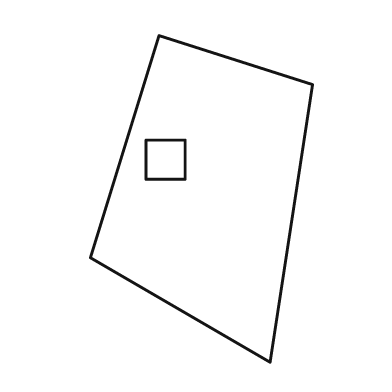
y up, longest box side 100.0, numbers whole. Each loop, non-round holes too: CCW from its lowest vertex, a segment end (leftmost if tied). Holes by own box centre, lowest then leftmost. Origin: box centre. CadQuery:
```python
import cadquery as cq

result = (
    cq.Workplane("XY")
    .moveTo(21.0, -50.0)
    .lineTo(34.0, 35.0)
    .lineTo(-13.0, 50.0)
    .lineTo(-34.0, -18.0)
    .close()
    .moveTo(-17.0, 6.0)
    .lineTo(-5.0, 6.0)
    .lineTo(-5.0, 18.0)
    .lineTo(-17.0, 18.0)
    .close()
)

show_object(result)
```